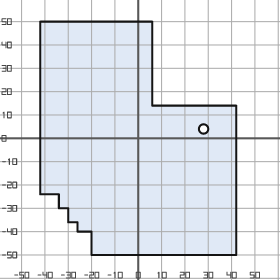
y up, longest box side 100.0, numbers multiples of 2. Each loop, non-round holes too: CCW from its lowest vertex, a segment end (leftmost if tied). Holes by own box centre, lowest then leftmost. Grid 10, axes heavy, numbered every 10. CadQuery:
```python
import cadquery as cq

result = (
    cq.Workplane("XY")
    .moveTo(-20.0, -50.0)
    .lineTo(42.0, -50.0)
    .lineTo(42.0, 14.0)
    .lineTo(6.0, 14.0)
    .lineTo(6.0, 50.0)
    .lineTo(-42.0, 50.0)
    .lineTo(-42.0, -24.0)
    .lineTo(-34.0, -24.0)
    .lineTo(-34.0, -30.0)
    .lineTo(-30.0, -30.0)
    .lineTo(-30.0, -36.0)
    .lineTo(-26.0, -36.0)
    .lineTo(-26.0, -40.0)
    .lineTo(-20.0, -40.0)
    .close()
    .moveTo(28.0, 4.0)
    .circle(2.0)
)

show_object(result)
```